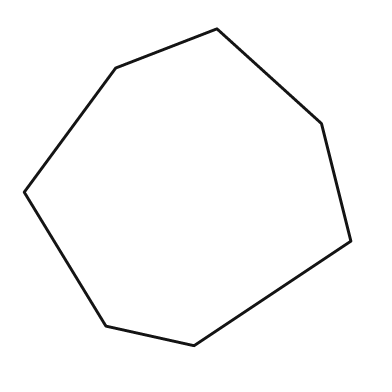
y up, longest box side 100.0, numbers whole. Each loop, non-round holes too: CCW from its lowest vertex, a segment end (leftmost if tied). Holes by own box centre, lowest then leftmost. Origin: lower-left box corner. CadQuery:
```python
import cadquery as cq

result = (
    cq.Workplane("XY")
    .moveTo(52.0, 0.0)
    .lineTo(100.0, 32.0)
    .lineTo(91.0, 68.0)
    .lineTo(59.0, 97.0)
    .lineTo(28.0, 85.0)
    .lineTo(0.0, 47.0)
    .lineTo(25.0, 6.0)
    .close()
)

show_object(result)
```